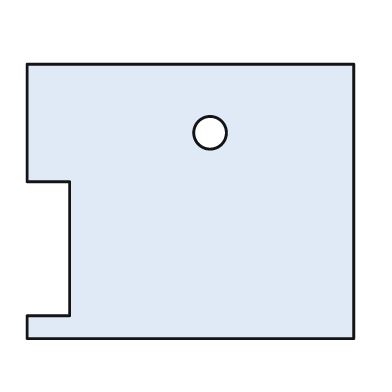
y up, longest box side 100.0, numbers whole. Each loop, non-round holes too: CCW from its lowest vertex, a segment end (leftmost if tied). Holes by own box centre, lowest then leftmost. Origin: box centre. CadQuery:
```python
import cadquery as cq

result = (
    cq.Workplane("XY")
    .moveTo(-50.0, -42.0)
    .lineTo(50.0, -42.0)
    .lineTo(50.0, 42.0)
    .lineTo(-50.0, 42.0)
    .lineTo(-50.0, 6.0)
    .lineTo(-37.0, 6.0)
    .lineTo(-37.0, -35.0)
    .lineTo(-50.0, -35.0)
    .close()
    .moveTo(6.0, 21.0)
    .circle(5.0)
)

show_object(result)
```